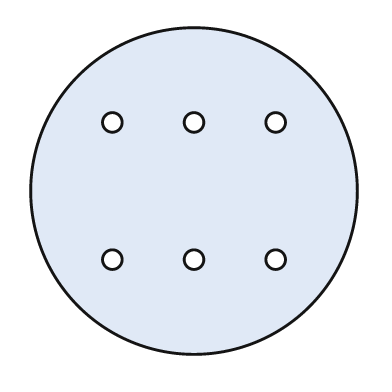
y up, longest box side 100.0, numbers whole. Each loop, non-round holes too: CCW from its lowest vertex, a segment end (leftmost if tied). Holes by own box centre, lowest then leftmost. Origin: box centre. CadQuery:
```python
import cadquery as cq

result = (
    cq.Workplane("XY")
    .moveTo(0.0, 0.0)
    .circle(50.0)
    .moveTo(-25.0, -21.0)
    .circle(3.0)
    .moveTo(0.0, -21.0)
    .circle(3.0)
    .moveTo(25.0, -21.0)
    .circle(3.0)
    .moveTo(-25.0, 21.0)
    .circle(3.0)
    .moveTo(0.0, 21.0)
    .circle(3.0)
    .moveTo(25.0, 21.0)
    .circle(3.0)
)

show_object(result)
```